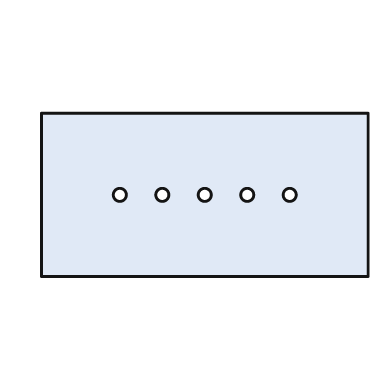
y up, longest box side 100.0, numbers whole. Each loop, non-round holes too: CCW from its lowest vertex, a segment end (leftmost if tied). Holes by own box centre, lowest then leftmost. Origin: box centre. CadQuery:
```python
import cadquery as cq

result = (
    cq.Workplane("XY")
    .moveTo(-50.0, -25.0)
    .lineTo(50.0, -25.0)
    .lineTo(50.0, 25.0)
    .lineTo(-50.0, 25.0)
    .close()
    .moveTo(-26.0, 0.0)
    .circle(2.0)
    .moveTo(-13.0, 0.0)
    .circle(2.0)
    .moveTo(0.0, 0.0)
    .circle(2.0)
    .moveTo(13.0, 0.0)
    .circle(2.0)
    .moveTo(26.0, 0.0)
    .circle(2.0)
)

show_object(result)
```